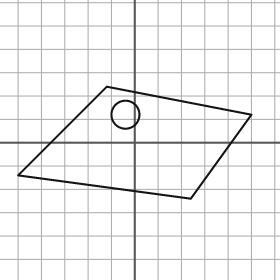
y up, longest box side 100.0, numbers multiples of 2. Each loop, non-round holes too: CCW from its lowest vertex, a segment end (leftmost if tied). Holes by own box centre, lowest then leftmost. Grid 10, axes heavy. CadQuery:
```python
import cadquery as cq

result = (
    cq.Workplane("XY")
    .moveTo(24.0, -24.0)
    .lineTo(50.0, 12.0)
    .lineTo(-12.0, 24.0)
    .lineTo(-50.0, -14.0)
    .close()
    .moveTo(-4.0, 12.0)
    .circle(6.0)
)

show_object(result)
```